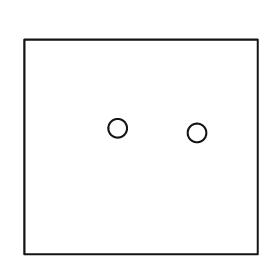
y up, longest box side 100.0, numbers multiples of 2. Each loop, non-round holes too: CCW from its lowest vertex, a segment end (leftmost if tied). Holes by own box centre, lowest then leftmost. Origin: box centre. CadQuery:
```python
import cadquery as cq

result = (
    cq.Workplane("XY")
    .moveTo(-50.0, -46.0)
    .lineTo(50.0, -46.0)
    .lineTo(50.0, 46.0)
    .lineTo(-50.0, 46.0)
    .close()
    .moveTo(24.0, 6.0)
    .circle(4.0)
    .moveTo(-10.0, 8.0)
    .circle(4.0)
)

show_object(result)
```